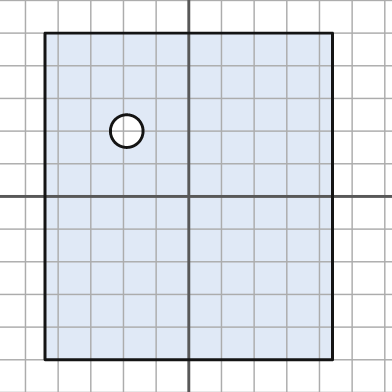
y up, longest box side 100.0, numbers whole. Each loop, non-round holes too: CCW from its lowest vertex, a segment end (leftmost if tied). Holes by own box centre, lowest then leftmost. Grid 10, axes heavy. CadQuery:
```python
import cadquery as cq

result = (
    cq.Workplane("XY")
    .moveTo(-44.0, -50.0)
    .lineTo(44.0, -50.0)
    .lineTo(44.0, 50.0)
    .lineTo(-44.0, 50.0)
    .close()
    .moveTo(-19.0, 20.0)
    .circle(5.0)
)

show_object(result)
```